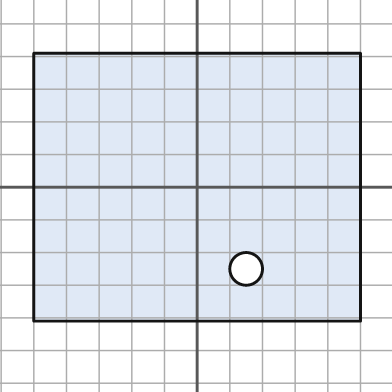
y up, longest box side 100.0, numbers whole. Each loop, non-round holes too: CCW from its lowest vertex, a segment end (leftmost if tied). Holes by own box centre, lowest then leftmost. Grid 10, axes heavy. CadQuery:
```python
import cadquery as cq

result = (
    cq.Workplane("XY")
    .moveTo(-50.0, -41.0)
    .lineTo(50.0, -41.0)
    .lineTo(50.0, 41.0)
    .lineTo(-50.0, 41.0)
    .close()
    .moveTo(15.0, -25.0)
    .circle(5.0)
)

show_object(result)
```